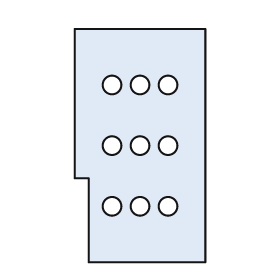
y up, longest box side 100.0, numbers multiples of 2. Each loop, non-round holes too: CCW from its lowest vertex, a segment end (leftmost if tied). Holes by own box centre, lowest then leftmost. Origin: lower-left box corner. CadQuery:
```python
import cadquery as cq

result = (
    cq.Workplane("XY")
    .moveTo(6.0, 0.0)
    .lineTo(56.0, 0.0)
    .lineTo(56.0, 100.0)
    .lineTo(0.0, 100.0)
    .lineTo(0.0, 36.0)
    .lineTo(6.0, 36.0)
    .close()
    .moveTo(16.0, 24.0)
    .circle(4.0)
    .moveTo(28.0, 24.0)
    .circle(4.0)
    .moveTo(40.0, 24.0)
    .circle(4.0)
    .moveTo(16.0, 50.0)
    .circle(4.0)
    .moveTo(28.0, 50.0)
    .circle(4.0)
    .moveTo(40.0, 50.0)
    .circle(4.0)
    .moveTo(16.0, 76.0)
    .circle(4.0)
    .moveTo(28.0, 76.0)
    .circle(4.0)
    .moveTo(40.0, 76.0)
    .circle(4.0)
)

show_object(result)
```